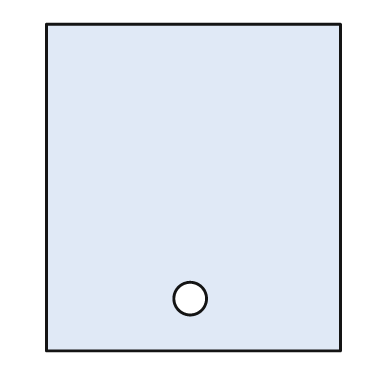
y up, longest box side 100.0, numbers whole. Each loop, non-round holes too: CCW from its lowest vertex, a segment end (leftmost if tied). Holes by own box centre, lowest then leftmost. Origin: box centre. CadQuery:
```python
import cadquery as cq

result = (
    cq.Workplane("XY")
    .moveTo(-45.0, -50.0)
    .lineTo(45.0, -50.0)
    .lineTo(45.0, 50.0)
    .lineTo(-45.0, 50.0)
    .close()
    .moveTo(-1.0, -34.0)
    .circle(5.0)
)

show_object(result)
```